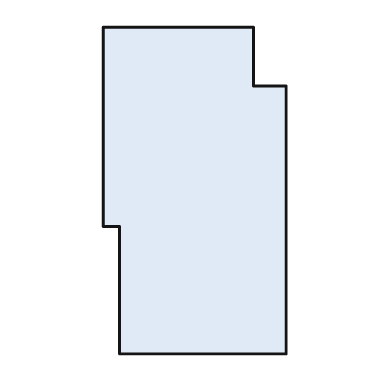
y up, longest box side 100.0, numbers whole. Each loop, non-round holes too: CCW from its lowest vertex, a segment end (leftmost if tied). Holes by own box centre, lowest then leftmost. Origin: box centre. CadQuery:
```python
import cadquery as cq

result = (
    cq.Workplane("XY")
    .moveTo(-23.0, -50.0)
    .lineTo(28.0, -50.0)
    .lineTo(28.0, 32.0)
    .lineTo(18.0, 32.0)
    .lineTo(18.0, 50.0)
    .lineTo(-28.0, 50.0)
    .lineTo(-28.0, -11.0)
    .lineTo(-23.0, -11.0)
    .close()
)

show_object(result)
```